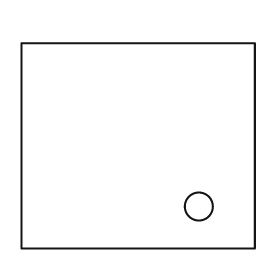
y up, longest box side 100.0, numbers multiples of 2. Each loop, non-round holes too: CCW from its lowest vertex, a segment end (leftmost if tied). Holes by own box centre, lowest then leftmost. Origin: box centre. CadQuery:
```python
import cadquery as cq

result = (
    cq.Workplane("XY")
    .moveTo(-50.0, -44.0)
    .lineTo(50.0, -44.0)
    .lineTo(50.0, 44.0)
    .lineTo(-50.0, 44.0)
    .close()
    .moveTo(26.0, -26.0)
    .circle(6.0)
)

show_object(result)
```